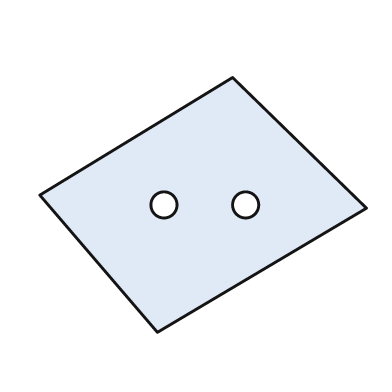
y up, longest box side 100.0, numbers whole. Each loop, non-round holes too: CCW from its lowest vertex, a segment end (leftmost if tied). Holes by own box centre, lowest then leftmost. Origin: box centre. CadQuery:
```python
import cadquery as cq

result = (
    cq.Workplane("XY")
    .moveTo(-14.0, -39.0)
    .lineTo(50.0, -1.0)
    .lineTo(9.0, 39.0)
    .lineTo(-50.0, 3.0)
    .close()
    .moveTo(-12.0, 0.0)
    .circle(4.0)
    .moveTo(13.0, 0.0)
    .circle(4.0)
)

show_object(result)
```